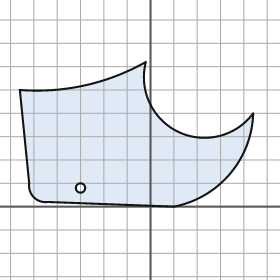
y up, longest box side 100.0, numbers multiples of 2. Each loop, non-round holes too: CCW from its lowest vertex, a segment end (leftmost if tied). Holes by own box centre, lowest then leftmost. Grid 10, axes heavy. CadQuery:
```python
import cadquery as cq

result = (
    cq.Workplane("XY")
    .moveTo(10.0, 0.0)
    .threePointArc((34.0, 14.0), (44.0, 40.0))
    .threePointArc((12.0, 32.0), (-2.0, 62.0))
    .threePointArc((-28.0, 52.0), (-56.0, 50.0))
    .lineTo(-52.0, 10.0)
    .threePointArc((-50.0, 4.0), (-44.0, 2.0))
    .close()
    .moveTo(-30.0, 8.0)
    .circle(2.0)
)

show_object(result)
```